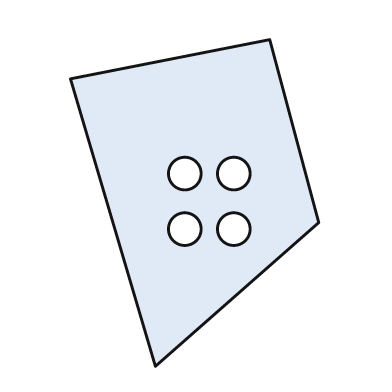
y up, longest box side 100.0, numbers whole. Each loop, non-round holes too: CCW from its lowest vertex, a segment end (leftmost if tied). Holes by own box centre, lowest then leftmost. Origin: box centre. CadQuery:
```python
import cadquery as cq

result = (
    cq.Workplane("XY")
    .moveTo(-12.0, -50.0)
    .lineTo(38.0, -6.0)
    .lineTo(23.0, 50.0)
    .lineTo(-38.0, 38.0)
    .close()
    .moveTo(-3.0, -8.0)
    .circle(5.0)
    .moveTo(12.0, -8.0)
    .circle(5.0)
    .moveTo(-3.0, 9.0)
    .circle(5.0)
    .moveTo(12.0, 9.0)
    .circle(5.0)
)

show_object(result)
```